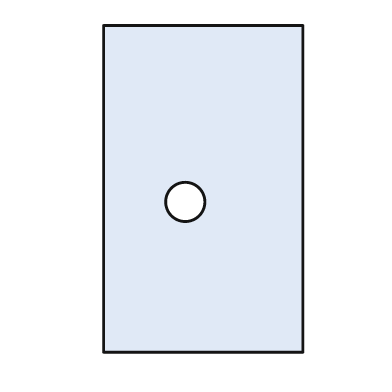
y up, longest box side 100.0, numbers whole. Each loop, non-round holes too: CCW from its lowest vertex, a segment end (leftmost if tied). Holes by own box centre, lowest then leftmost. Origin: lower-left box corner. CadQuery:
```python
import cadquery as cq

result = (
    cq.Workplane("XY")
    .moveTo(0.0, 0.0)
    .lineTo(61.0, 0.0)
    .lineTo(61.0, 100.0)
    .lineTo(0.0, 100.0)
    .close()
    .moveTo(25.0, 46.0)
    .circle(6.0)
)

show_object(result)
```